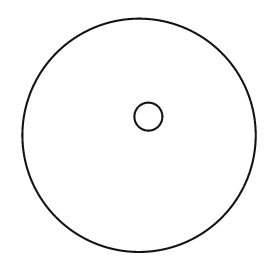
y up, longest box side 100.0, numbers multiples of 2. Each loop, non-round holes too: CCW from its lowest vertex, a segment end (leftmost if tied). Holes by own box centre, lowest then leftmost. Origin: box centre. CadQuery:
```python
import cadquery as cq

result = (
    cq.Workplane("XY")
    .moveTo(0.0, 0.0)
    .circle(50.0)
    .moveTo(4.0, 8.0)
    .circle(6.0)
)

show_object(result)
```